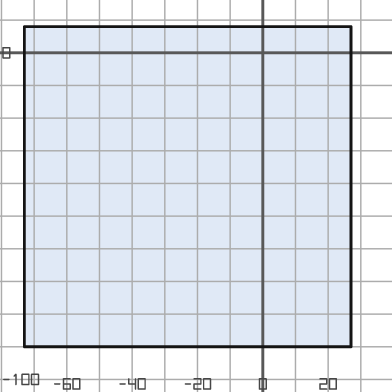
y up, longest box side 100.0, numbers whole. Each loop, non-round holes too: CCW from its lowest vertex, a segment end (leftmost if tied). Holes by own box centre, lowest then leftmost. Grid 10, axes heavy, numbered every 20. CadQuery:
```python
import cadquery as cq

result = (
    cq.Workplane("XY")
    .moveTo(-73.0, -90.0)
    .lineTo(27.0, -90.0)
    .lineTo(27.0, 8.0)
    .lineTo(-73.0, 8.0)
    .close()
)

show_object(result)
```